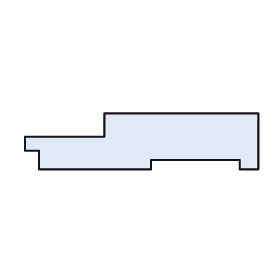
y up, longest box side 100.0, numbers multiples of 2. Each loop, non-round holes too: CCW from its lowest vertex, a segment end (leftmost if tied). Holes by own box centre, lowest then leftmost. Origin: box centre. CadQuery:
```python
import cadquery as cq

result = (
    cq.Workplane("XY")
    .moveTo(-44.0, -12.0)
    .lineTo(4.0, -12.0)
    .lineTo(4.0, -8.0)
    .lineTo(42.0, -8.0)
    .lineTo(42.0, -12.0)
    .lineTo(50.0, -12.0)
    .lineTo(50.0, 12.0)
    .lineTo(-16.0, 12.0)
    .lineTo(-16.0, 2.0)
    .lineTo(-50.0, 2.0)
    .lineTo(-50.0, -4.0)
    .lineTo(-44.0, -4.0)
    .close()
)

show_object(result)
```